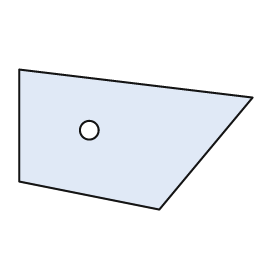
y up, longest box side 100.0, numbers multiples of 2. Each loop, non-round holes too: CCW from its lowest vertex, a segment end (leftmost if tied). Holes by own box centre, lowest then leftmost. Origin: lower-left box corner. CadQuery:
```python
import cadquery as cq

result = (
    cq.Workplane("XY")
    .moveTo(60.0, 0.0)
    .lineTo(100.0, 48.0)
    .lineTo(0.0, 60.0)
    .lineTo(0.0, 12.0)
    .close()
    .moveTo(30.0, 34.0)
    .circle(4.0)
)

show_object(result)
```